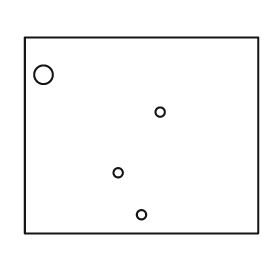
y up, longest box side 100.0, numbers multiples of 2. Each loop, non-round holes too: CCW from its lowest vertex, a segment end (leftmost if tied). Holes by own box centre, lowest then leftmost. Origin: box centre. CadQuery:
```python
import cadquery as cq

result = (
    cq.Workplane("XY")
    .moveTo(-50.0, -42.0)
    .lineTo(50.0, -42.0)
    .lineTo(50.0, 42.0)
    .lineTo(-50.0, 42.0)
    .close()
    .moveTo(0.0, -34.0)
    .circle(2.0)
    .moveTo(-10.0, -16.0)
    .circle(2.0)
    .moveTo(8.0, 10.0)
    .circle(2.0)
    .moveTo(-42.0, 26.0)
    .circle(4.0)
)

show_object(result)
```